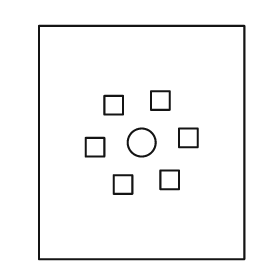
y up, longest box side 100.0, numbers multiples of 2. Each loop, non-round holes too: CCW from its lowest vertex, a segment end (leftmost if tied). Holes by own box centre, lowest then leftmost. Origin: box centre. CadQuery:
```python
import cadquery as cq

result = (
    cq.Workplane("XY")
    .moveTo(-44.0, -50.0)
    .lineTo(44.0, -50.0)
    .lineTo(44.0, 50.0)
    .lineTo(-44.0, 50.0)
    .close()
    .moveTo(-12.0, -22.0)
    .lineTo(-4.0, -22.0)
    .lineTo(-4.0, -14.0)
    .lineTo(-12.0, -14.0)
    .close()
    .moveTo(8.0, -20.0)
    .lineTo(16.0, -20.0)
    .lineTo(16.0, -12.0)
    .lineTo(8.0, -12.0)
    .close()
    .moveTo(-24.0, -6.0)
    .lineTo(-16.0, -6.0)
    .lineTo(-16.0, 2.0)
    .lineTo(-24.0, 2.0)
    .close()
    .moveTo(0.0, 0.0)
    .circle(6.0)
    .moveTo(16.0, -2.0)
    .lineTo(24.0, -2.0)
    .lineTo(24.0, 6.0)
    .lineTo(16.0, 6.0)
    .close()
    .moveTo(-16.0, 12.0)
    .lineTo(-8.0, 12.0)
    .lineTo(-8.0, 20.0)
    .lineTo(-16.0, 20.0)
    .close()
    .moveTo(4.0, 14.0)
    .lineTo(12.0, 14.0)
    .lineTo(12.0, 22.0)
    .lineTo(4.0, 22.0)
    .close()
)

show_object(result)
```